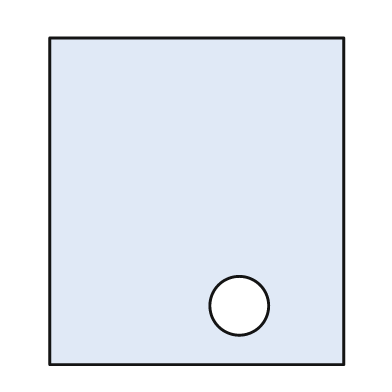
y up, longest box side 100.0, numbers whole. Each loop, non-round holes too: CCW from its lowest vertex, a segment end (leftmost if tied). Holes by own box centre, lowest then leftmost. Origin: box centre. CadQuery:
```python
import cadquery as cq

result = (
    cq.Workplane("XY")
    .moveTo(-45.0, -50.0)
    .lineTo(45.0, -50.0)
    .lineTo(45.0, 50.0)
    .lineTo(-45.0, 50.0)
    .close()
    .moveTo(13.0, -32.0)
    .circle(9.0)
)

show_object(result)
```